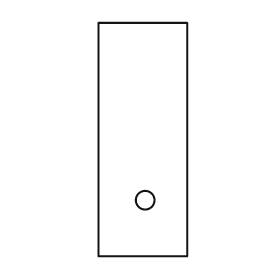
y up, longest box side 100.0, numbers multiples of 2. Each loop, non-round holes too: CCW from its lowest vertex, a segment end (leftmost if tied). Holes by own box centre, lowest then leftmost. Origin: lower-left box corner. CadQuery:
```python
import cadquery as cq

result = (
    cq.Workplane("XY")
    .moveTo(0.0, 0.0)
    .lineTo(38.0, 0.0)
    .lineTo(38.0, 100.0)
    .lineTo(0.0, 100.0)
    .close()
    .moveTo(20.0, 24.0)
    .circle(4.0)
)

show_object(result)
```